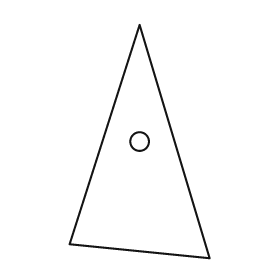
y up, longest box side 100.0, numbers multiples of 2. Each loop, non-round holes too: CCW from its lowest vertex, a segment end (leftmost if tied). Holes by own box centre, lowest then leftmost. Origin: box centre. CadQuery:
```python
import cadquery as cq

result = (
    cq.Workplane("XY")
    .moveTo(30.0, -50.0)
    .lineTo(0.0, 50.0)
    .lineTo(-30.0, -44.0)
    .close()
    .moveTo(0.0, 0.0)
    .circle(4.0)
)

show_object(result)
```